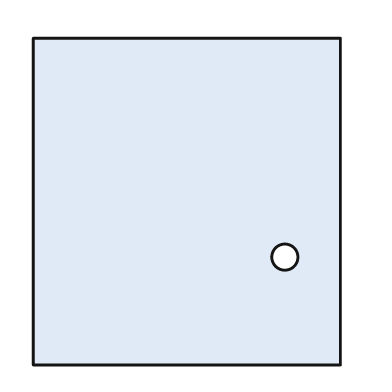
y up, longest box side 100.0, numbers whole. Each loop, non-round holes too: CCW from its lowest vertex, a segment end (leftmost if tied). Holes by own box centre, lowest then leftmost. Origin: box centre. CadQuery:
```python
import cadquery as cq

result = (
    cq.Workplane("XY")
    .moveTo(-47.0, -50.0)
    .lineTo(47.0, -50.0)
    .lineTo(47.0, 50.0)
    .lineTo(-47.0, 50.0)
    .close()
    .moveTo(30.0, -17.0)
    .circle(4.0)
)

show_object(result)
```